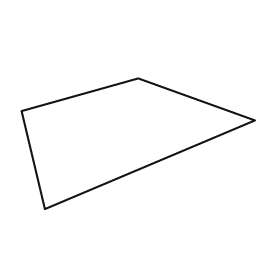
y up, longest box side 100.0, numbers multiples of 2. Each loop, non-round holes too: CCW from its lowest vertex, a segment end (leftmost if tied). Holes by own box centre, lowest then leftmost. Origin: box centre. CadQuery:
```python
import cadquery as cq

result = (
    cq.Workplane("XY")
    .moveTo(-40.0, -28.0)
    .lineTo(50.0, 10.0)
    .lineTo(0.0, 28.0)
    .lineTo(-50.0, 14.0)
    .close()
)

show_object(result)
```